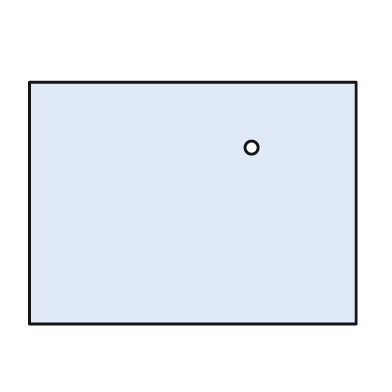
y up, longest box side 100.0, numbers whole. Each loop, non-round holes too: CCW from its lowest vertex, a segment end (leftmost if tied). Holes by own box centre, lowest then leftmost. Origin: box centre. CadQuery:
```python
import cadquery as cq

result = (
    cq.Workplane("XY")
    .moveTo(-50.0, -37.0)
    .lineTo(50.0, -37.0)
    .lineTo(50.0, 37.0)
    .lineTo(-50.0, 37.0)
    .close()
    .moveTo(18.0, 17.0)
    .circle(2.0)
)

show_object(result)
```